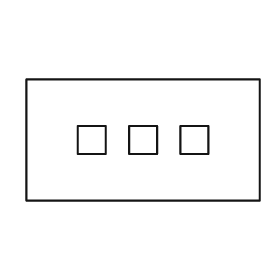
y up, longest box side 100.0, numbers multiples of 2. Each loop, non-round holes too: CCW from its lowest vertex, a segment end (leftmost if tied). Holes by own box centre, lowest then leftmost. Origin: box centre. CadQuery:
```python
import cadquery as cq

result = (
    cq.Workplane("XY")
    .moveTo(-50.0, -26.0)
    .lineTo(50.0, -26.0)
    .lineTo(50.0, 26.0)
    .lineTo(-50.0, 26.0)
    .close()
    .moveTo(-28.0, -6.0)
    .lineTo(-16.0, -6.0)
    .lineTo(-16.0, 6.0)
    .lineTo(-28.0, 6.0)
    .close()
    .moveTo(-6.0, -6.0)
    .lineTo(6.0, -6.0)
    .lineTo(6.0, 6.0)
    .lineTo(-6.0, 6.0)
    .close()
    .moveTo(16.0, -6.0)
    .lineTo(28.0, -6.0)
    .lineTo(28.0, 6.0)
    .lineTo(16.0, 6.0)
    .close()
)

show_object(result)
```